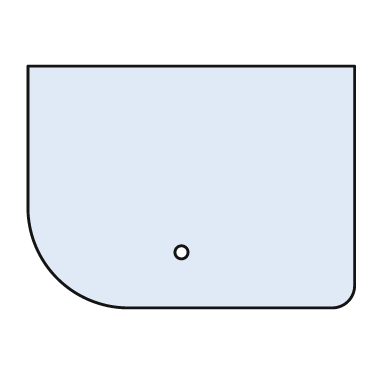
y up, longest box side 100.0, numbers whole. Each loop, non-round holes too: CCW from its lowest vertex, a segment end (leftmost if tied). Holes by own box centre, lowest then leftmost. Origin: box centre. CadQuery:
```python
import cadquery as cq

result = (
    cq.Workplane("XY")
    .moveTo(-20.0, -37.0)
    .lineTo(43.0, -37.0)
    .threePointArc((48.0, -35.0), (50.0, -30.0))
    .lineTo(50.0, 37.0)
    .lineTo(-50.0, 37.0)
    .lineTo(-50.0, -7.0)
    .threePointArc((-41.0, -28.0), (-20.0, -37.0))
    .close()
    .moveTo(-3.0, -20.0)
    .circle(2.0)
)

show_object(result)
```